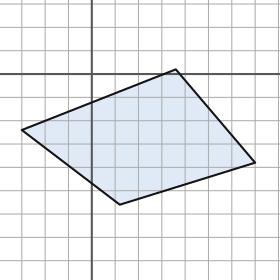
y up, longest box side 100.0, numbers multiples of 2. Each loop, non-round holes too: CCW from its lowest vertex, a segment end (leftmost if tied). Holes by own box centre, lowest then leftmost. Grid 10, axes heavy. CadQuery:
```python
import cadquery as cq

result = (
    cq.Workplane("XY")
    .moveTo(12.0, -56.0)
    .lineTo(70.0, -38.0)
    .lineTo(36.0, 2.0)
    .lineTo(-30.0, -24.0)
    .close()
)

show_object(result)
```